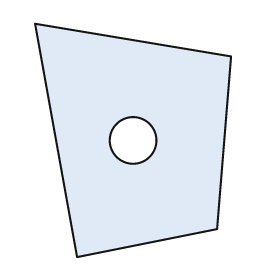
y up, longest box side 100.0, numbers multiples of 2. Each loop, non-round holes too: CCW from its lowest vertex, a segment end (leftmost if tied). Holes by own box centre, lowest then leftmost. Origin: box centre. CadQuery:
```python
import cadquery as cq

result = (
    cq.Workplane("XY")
    .moveTo(-24.0, -50.0)
    .lineTo(36.0, -38.0)
    .lineTo(42.0, 36.0)
    .lineTo(-42.0, 50.0)
    .close()
    .moveTo(0.0, 0.0)
    .circle(10.0)
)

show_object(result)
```